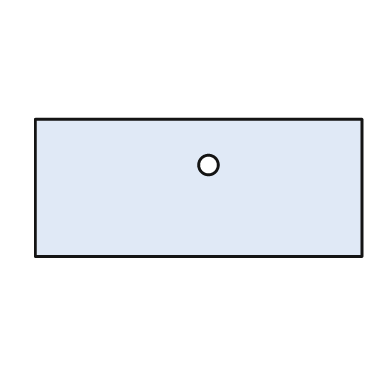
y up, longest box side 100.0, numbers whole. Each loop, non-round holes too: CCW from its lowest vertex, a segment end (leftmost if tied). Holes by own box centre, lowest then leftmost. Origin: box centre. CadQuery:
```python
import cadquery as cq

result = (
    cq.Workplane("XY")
    .moveTo(-50.0, -21.0)
    .lineTo(50.0, -21.0)
    .lineTo(50.0, 21.0)
    .lineTo(-50.0, 21.0)
    .close()
    .moveTo(3.0, 7.0)
    .circle(3.0)
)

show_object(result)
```